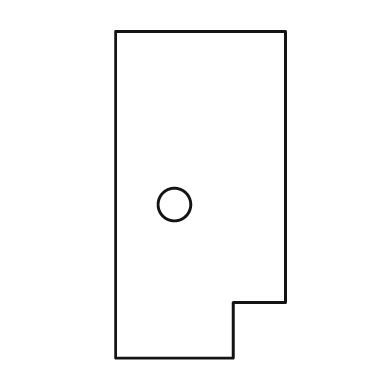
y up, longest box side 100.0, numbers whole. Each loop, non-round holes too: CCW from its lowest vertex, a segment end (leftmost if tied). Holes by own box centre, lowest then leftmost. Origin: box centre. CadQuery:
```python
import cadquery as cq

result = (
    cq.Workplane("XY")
    .moveTo(-26.0, -50.0)
    .lineTo(10.0, -50.0)
    .lineTo(10.0, -33.0)
    .lineTo(26.0, -33.0)
    .lineTo(26.0, 50.0)
    .lineTo(-26.0, 50.0)
    .close()
    .moveTo(-8.0, -3.0)
    .circle(5.0)
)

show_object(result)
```